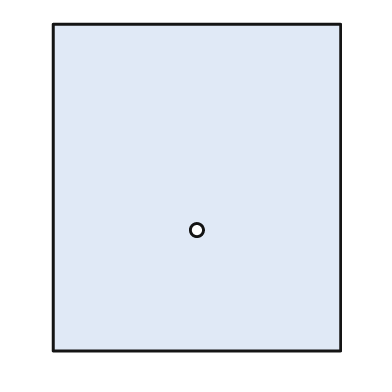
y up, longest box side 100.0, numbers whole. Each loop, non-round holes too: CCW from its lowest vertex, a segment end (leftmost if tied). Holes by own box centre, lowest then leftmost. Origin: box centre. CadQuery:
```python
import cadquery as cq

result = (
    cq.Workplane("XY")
    .moveTo(-44.0, -50.0)
    .lineTo(44.0, -50.0)
    .lineTo(44.0, 50.0)
    .lineTo(-44.0, 50.0)
    .close()
    .moveTo(0.0, -13.0)
    .circle(2.0)
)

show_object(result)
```